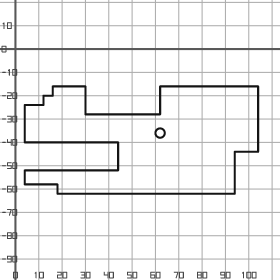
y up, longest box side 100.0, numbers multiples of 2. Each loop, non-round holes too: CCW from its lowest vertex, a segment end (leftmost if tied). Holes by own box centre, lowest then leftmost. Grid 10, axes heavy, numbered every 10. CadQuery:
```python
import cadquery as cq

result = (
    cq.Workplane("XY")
    .moveTo(18.0, -62.0)
    .lineTo(94.0, -62.0)
    .lineTo(94.0, -44.0)
    .lineTo(104.0, -44.0)
    .lineTo(104.0, -16.0)
    .lineTo(62.0, -16.0)
    .lineTo(62.0, -28.0)
    .lineTo(30.0, -28.0)
    .lineTo(30.0, -16.0)
    .lineTo(16.0, -16.0)
    .lineTo(16.0, -20.0)
    .lineTo(12.0, -20.0)
    .lineTo(12.0, -24.0)
    .lineTo(4.0, -24.0)
    .lineTo(4.0, -40.0)
    .lineTo(44.0, -40.0)
    .lineTo(44.0, -52.0)
    .lineTo(4.0, -52.0)
    .lineTo(4.0, -58.0)
    .lineTo(18.0, -58.0)
    .close()
    .moveTo(62.0, -36.0)
    .circle(2.0)
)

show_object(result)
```